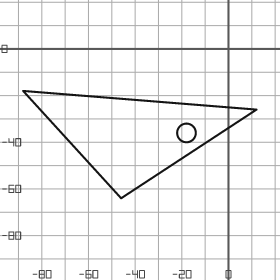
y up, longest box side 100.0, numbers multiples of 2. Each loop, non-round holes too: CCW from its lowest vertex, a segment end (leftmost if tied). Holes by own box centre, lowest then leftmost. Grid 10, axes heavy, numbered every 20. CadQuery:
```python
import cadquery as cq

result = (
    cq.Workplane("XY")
    .moveTo(-46.0, -64.0)
    .lineTo(12.0, -26.0)
    .lineTo(-88.0, -18.0)
    .close()
    .moveTo(-18.0, -36.0)
    .circle(4.0)
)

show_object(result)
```